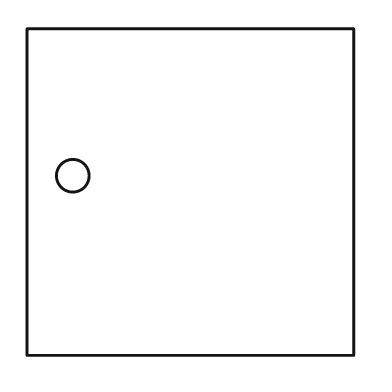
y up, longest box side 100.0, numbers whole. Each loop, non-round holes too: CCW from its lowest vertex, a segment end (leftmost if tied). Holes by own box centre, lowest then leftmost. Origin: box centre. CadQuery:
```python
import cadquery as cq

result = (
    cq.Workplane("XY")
    .moveTo(-50.0, -50.0)
    .lineTo(50.0, -50.0)
    .lineTo(50.0, 50.0)
    .lineTo(-50.0, 50.0)
    .close()
    .moveTo(-36.0, 5.0)
    .circle(5.0)
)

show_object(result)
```